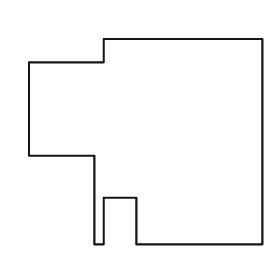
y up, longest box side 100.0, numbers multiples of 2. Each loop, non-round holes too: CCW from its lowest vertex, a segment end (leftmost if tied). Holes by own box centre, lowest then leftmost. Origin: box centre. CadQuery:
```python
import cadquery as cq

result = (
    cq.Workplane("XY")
    .moveTo(-22.0, -44.0)
    .lineTo(-18.0, -44.0)
    .lineTo(-18.0, -24.0)
    .lineTo(-4.0, -24.0)
    .lineTo(-4.0, -44.0)
    .lineTo(50.0, -44.0)
    .lineTo(50.0, 44.0)
    .lineTo(-18.0, 44.0)
    .lineTo(-18.0, 34.0)
    .lineTo(-50.0, 34.0)
    .lineTo(-50.0, -6.0)
    .lineTo(-22.0, -6.0)
    .close()
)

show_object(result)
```